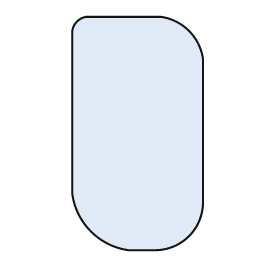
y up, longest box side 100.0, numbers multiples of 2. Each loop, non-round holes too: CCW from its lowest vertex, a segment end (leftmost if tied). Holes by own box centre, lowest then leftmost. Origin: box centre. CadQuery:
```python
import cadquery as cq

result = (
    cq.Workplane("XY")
    .moveTo(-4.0, -50.0)
    .lineTo(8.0, -50.0)
    .threePointArc((22.0, -44.0), (28.0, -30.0))
    .lineTo(28.0, 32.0)
    .threePointArc((22.0, 44.0), (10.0, 50.0))
    .lineTo(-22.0, 50.0)
    .threePointArc((-26.0, 48.0), (-28.0, 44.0))
    .lineTo(-28.0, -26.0)
    .threePointArc((-20.0, -42.0), (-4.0, -50.0))
    .close()
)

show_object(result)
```